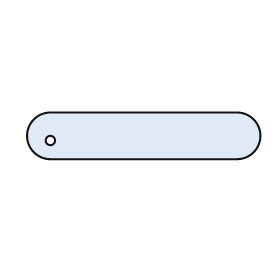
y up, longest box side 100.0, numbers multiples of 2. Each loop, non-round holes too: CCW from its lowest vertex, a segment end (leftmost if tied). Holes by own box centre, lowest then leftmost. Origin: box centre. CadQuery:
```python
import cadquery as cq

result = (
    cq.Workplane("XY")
    .moveTo(-40.0, -10.0)
    .lineTo(40.0, -10.0)
    .threePointArc((50.0, 0.0), (40.0, 10.0))
    .lineTo(-40.0, 10.0)
    .threePointArc((-50.0, 0.0), (-40.0, -10.0))
    .close()
    .moveTo(-40.0, -2.0)
    .circle(2.0)
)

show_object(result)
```